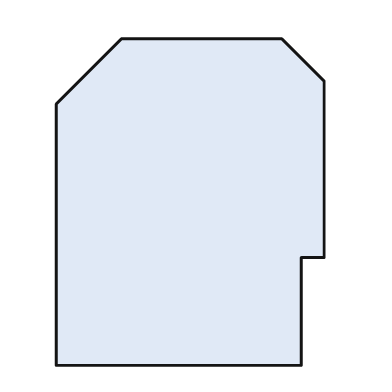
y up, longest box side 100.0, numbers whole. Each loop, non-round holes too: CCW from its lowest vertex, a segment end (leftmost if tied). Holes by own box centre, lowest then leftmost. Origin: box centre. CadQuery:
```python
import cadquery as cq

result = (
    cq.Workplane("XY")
    .moveTo(-41.0, -50.0)
    .lineTo(34.0, -50.0)
    .lineTo(34.0, -17.0)
    .lineTo(41.0, -17.0)
    .lineTo(41.0, 37.0)
    .lineTo(28.0, 50.0)
    .lineTo(-21.0, 50.0)
    .lineTo(-41.0, 30.0)
    .close()
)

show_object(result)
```